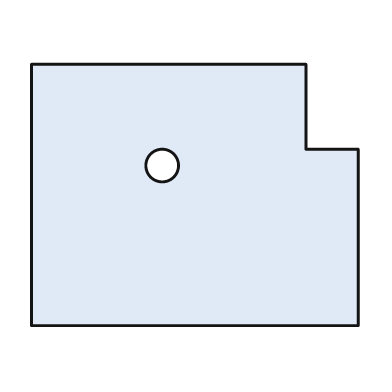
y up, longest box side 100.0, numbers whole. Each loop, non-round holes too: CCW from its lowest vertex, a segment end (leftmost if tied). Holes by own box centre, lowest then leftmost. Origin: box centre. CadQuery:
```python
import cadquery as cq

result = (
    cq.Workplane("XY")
    .moveTo(-50.0, -40.0)
    .lineTo(50.0, -40.0)
    .lineTo(50.0, 14.0)
    .lineTo(34.0, 14.0)
    .lineTo(34.0, 40.0)
    .lineTo(-50.0, 40.0)
    .close()
    .moveTo(-10.0, 9.0)
    .circle(5.0)
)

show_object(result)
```